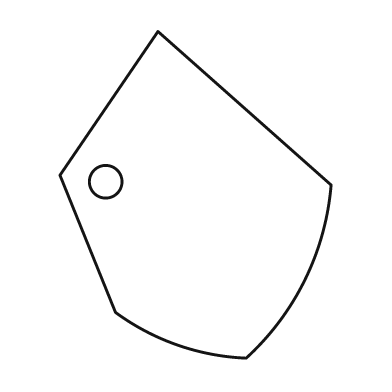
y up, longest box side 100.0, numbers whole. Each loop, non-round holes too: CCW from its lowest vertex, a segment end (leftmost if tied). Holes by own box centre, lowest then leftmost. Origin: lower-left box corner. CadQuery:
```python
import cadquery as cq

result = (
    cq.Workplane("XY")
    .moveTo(57.0, 0.0)
    .threePointArc((75.0, 24.0), (83.0, 53.0))
    .lineTo(30.0, 100.0)
    .lineTo(0.0, 56.0)
    .lineTo(17.0, 14.0)
    .threePointArc((36.0, 4.0), (57.0, 0.0))
    .close()
    .moveTo(14.0, 54.0)
    .circle(5.0)
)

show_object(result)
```